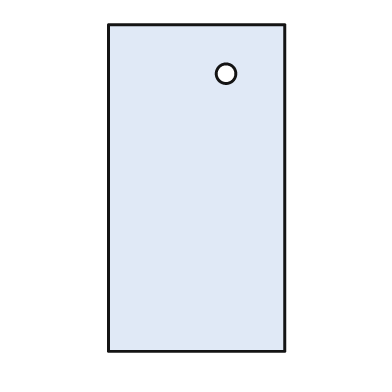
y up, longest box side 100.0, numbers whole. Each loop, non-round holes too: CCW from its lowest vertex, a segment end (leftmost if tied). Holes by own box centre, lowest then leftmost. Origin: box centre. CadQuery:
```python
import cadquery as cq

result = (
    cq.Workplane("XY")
    .moveTo(-27.0, -50.0)
    .lineTo(27.0, -50.0)
    .lineTo(27.0, 50.0)
    .lineTo(-27.0, 50.0)
    .close()
    .moveTo(9.0, 35.0)
    .circle(3.0)
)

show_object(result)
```